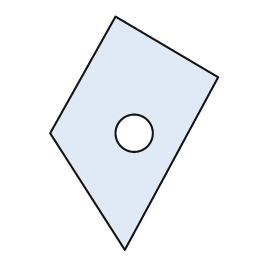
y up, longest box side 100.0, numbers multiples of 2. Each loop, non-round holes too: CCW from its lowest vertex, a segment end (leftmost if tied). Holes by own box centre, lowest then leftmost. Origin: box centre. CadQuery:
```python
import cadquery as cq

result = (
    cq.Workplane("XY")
    .moveTo(-4.0, -50.0)
    .lineTo(36.0, 24.0)
    .lineTo(-8.0, 50.0)
    .lineTo(-36.0, 0.0)
    .close()
    .moveTo(0.0, 0.0)
    .circle(8.0)
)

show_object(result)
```